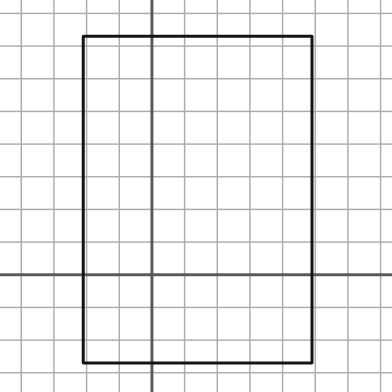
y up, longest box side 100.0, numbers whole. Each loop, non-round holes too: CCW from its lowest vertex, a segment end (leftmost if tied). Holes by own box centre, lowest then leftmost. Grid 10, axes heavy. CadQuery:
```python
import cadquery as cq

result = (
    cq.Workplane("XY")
    .moveTo(-21.0, -27.0)
    .lineTo(49.0, -27.0)
    .lineTo(49.0, 73.0)
    .lineTo(-21.0, 73.0)
    .close()
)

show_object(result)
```